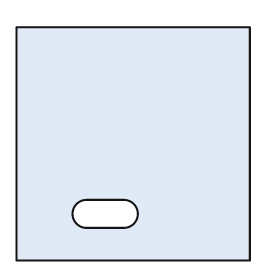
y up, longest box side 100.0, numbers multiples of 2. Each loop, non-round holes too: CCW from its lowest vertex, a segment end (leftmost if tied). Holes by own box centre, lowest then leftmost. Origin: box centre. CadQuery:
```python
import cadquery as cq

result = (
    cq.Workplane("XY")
    .moveTo(-50.0, -50.0)
    .lineTo(50.0, -50.0)
    .lineTo(50.0, 50.0)
    .lineTo(-50.0, 50.0)
    .close()
    .moveTo(-20.0, -36.0)
    .lineTo(-4.0, -36.0)
    .threePointArc((2.0, -30.0), (-4.0, -24.0))
    .lineTo(-20.0, -24.0)
    .threePointArc((-26.0, -30.0), (-20.0, -36.0))
    .close()
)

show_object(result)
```